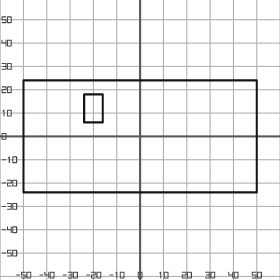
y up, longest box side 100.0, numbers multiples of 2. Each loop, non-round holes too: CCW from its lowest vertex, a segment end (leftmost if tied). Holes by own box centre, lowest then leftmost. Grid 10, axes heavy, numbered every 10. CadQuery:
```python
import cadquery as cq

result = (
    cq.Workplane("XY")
    .moveTo(-50.0, -24.0)
    .lineTo(50.0, -24.0)
    .lineTo(50.0, 24.0)
    .lineTo(-50.0, 24.0)
    .close()
    .moveTo(-24.0, 6.0)
    .lineTo(-16.0, 6.0)
    .lineTo(-16.0, 18.0)
    .lineTo(-24.0, 18.0)
    .close()
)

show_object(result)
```